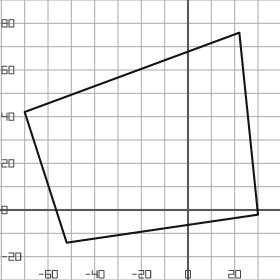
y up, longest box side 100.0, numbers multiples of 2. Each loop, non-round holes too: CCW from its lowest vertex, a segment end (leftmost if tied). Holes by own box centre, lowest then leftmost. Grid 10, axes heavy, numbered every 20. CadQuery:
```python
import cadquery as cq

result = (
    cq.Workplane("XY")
    .moveTo(-52.0, -14.0)
    .lineTo(30.0, -2.0)
    .lineTo(22.0, 76.0)
    .lineTo(-70.0, 42.0)
    .close()
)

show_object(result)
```